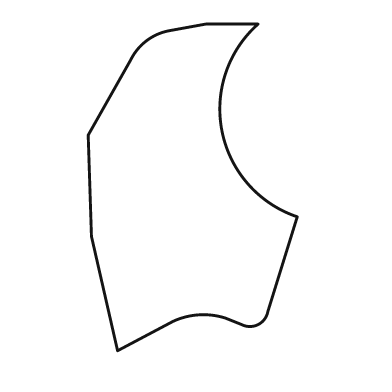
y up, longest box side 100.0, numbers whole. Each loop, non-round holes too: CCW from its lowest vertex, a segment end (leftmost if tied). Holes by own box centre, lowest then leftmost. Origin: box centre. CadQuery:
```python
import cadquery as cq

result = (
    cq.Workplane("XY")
    .moveTo(-23.0, -50.0)
    .lineTo(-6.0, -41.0)
    .threePointArc((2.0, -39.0), (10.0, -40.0))
    .lineTo(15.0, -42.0)
    .threePointArc((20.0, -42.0), (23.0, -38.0))
    .lineTo(32.0, -9.0)
    .threePointArc((9.0, 17.0), (20.0, 50.0))
    .lineTo(4.0, 50.0)
    .lineTo(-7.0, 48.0)
    .threePointArc((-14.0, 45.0), (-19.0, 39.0))
    .lineTo(-32.0, 16.0)
    .lineTo(-31.0, -15.0)
    .close()
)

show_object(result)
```